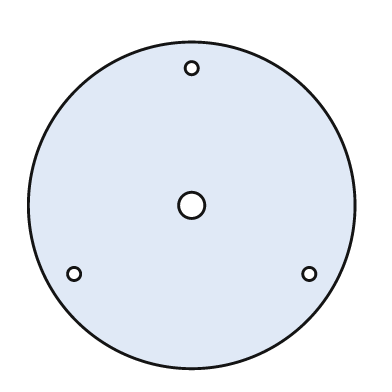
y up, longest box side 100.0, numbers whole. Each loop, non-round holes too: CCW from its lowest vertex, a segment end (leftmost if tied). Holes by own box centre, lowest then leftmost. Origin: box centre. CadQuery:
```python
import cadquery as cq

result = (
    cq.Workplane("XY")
    .moveTo(0.0, 0.0)
    .circle(50.0)
    .moveTo(-36.0, -21.0)
    .circle(2.0)
    .moveTo(36.0, -21.0)
    .circle(2.0)
    .moveTo(0.0, 0.0)
    .circle(4.0)
    .moveTo(0.0, 42.0)
    .circle(2.0)
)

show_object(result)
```